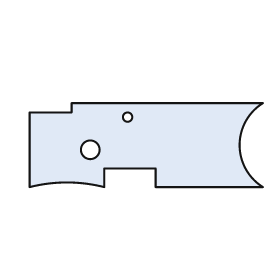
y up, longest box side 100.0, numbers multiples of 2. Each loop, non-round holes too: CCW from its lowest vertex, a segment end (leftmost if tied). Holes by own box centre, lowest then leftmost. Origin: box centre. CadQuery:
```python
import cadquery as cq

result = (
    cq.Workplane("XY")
    .moveTo(-50.0, -18.0)
    .threePointArc((-34.0, -16.0), (-18.0, -18.0))
    .lineTo(-18.0, -10.0)
    .lineTo(4.0, -10.0)
    .lineTo(4.0, -18.0)
    .lineTo(50.0, -18.0)
    .threePointArc((40.0, 0.0), (50.0, 18.0))
    .lineTo(-32.0, 18.0)
    .lineTo(-32.0, 14.0)
    .lineTo(-50.0, 14.0)
    .close()
    .moveTo(-24.0, -2.0)
    .circle(4.0)
    .moveTo(-8.0, 12.0)
    .circle(2.0)
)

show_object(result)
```